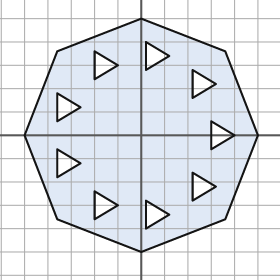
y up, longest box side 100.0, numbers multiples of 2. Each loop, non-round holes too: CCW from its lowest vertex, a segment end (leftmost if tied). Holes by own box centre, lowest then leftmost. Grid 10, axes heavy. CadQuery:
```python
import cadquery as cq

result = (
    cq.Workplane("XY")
    .moveTo(0.0, -50.0)
    .lineTo(36.0, -36.0)
    .lineTo(50.0, 0.0)
    .lineTo(36.0, 36.0)
    .lineTo(0.0, 50.0)
    .lineTo(-36.0, 36.0)
    .lineTo(-50.0, 0.0)
    .lineTo(-36.0, -36.0)
    .close()
    .moveTo(2.0, -40.0)
    .lineTo(12.0, -34.0)
    .lineTo(2.0, -28.0)
    .close()
    .moveTo(-20.0, -36.0)
    .lineTo(-10.0, -30.0)
    .lineTo(-20.0, -24.0)
    .close()
    .moveTo(22.0, -28.0)
    .lineTo(32.0, -22.0)
    .lineTo(22.0, -16.0)
    .close()
    .moveTo(-36.0, -18.0)
    .lineTo(-26.0, -12.0)
    .lineTo(-36.0, -6.0)
    .close()
    .moveTo(30.0, -6.0)
    .lineTo(40.0, 0.0)
    .lineTo(30.0, 6.0)
    .close()
    .moveTo(-36.0, 6.0)
    .lineTo(-26.0, 12.0)
    .lineTo(-36.0, 18.0)
    .close()
    .moveTo(22.0, 16.0)
    .lineTo(32.0, 22.0)
    .lineTo(22.0, 28.0)
    .close()
    .moveTo(-20.0, 24.0)
    .lineTo(-10.0, 30.0)
    .lineTo(-20.0, 36.0)
    .close()
    .moveTo(2.0, 28.0)
    .lineTo(12.0, 34.0)
    .lineTo(2.0, 40.0)
    .close()
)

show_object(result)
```